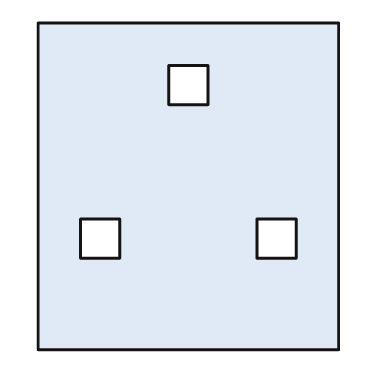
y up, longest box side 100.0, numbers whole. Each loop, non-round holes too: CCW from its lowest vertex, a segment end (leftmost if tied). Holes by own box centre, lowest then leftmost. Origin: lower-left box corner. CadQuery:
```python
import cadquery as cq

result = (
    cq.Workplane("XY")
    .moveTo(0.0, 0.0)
    .lineTo(92.0, 0.0)
    .lineTo(92.0, 100.0)
    .lineTo(0.0, 100.0)
    .close()
    .moveTo(13.0, 28.0)
    .lineTo(25.0, 28.0)
    .lineTo(25.0, 40.0)
    .lineTo(13.0, 40.0)
    .close()
    .moveTo(67.0, 28.0)
    .lineTo(79.0, 28.0)
    .lineTo(79.0, 40.0)
    .lineTo(67.0, 40.0)
    .close()
    .moveTo(40.0, 75.0)
    .lineTo(52.0, 75.0)
    .lineTo(52.0, 87.0)
    .lineTo(40.0, 87.0)
    .close()
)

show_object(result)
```